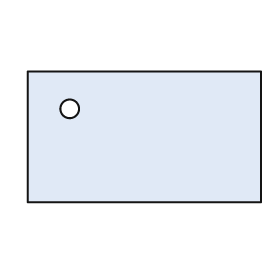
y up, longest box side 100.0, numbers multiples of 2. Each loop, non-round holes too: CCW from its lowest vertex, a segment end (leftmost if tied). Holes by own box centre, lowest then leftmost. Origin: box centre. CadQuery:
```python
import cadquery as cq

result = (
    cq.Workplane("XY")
    .moveTo(-50.0, -28.0)
    .lineTo(50.0, -28.0)
    .lineTo(50.0, 28.0)
    .lineTo(-50.0, 28.0)
    .close()
    .moveTo(-32.0, 12.0)
    .circle(4.0)
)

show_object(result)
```